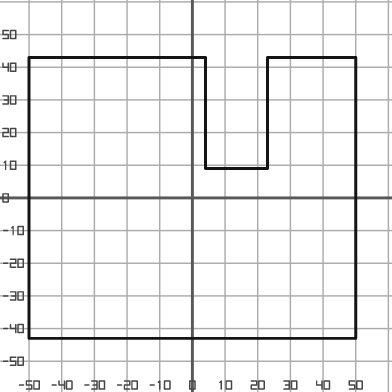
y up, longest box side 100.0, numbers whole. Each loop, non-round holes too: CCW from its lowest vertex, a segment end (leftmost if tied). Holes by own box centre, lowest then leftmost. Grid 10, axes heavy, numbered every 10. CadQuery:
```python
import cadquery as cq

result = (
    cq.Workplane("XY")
    .moveTo(-50.0, -43.0)
    .lineTo(50.0, -43.0)
    .lineTo(50.0, 43.0)
    .lineTo(23.0, 43.0)
    .lineTo(23.0, 9.0)
    .lineTo(4.0, 9.0)
    .lineTo(4.0, 43.0)
    .lineTo(-50.0, 43.0)
    .close()
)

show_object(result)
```